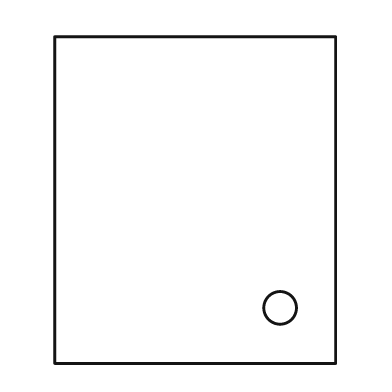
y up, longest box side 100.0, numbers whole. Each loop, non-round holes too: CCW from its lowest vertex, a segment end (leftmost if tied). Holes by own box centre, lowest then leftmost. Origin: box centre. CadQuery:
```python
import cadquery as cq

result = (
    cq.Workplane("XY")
    .moveTo(-43.0, -50.0)
    .lineTo(43.0, -50.0)
    .lineTo(43.0, 50.0)
    .lineTo(-43.0, 50.0)
    .close()
    .moveTo(26.0, -33.0)
    .circle(5.0)
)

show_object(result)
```